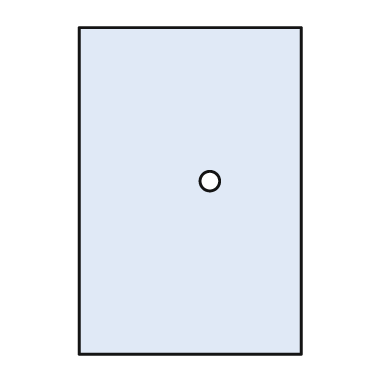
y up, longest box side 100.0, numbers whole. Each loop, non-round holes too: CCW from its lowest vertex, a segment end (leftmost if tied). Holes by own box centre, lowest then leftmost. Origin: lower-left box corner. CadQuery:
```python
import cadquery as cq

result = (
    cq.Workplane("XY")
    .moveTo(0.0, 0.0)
    .lineTo(68.0, 0.0)
    .lineTo(68.0, 100.0)
    .lineTo(0.0, 100.0)
    .close()
    .moveTo(40.0, 53.0)
    .circle(3.0)
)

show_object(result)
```